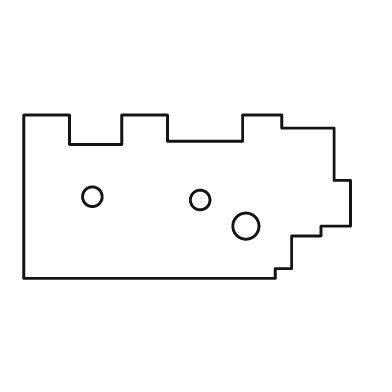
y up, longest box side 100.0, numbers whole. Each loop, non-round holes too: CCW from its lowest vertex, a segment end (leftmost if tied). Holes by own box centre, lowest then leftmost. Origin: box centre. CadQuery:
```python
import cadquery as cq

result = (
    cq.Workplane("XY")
    .moveTo(-50.0, -25.0)
    .lineTo(27.0, -25.0)
    .lineTo(27.0, -22.0)
    .lineTo(32.0, -22.0)
    .lineTo(32.0, -12.0)
    .lineTo(41.0, -12.0)
    .lineTo(41.0, -9.0)
    .lineTo(50.0, -9.0)
    .lineTo(50.0, 5.0)
    .lineTo(45.0, 5.0)
    .lineTo(45.0, 21.0)
    .lineTo(29.0, 21.0)
    .lineTo(29.0, 25.0)
    .lineTo(17.0, 25.0)
    .lineTo(17.0, 17.0)
    .lineTo(-6.0, 17.0)
    .lineTo(-6.0, 25.0)
    .lineTo(-20.0, 25.0)
    .lineTo(-20.0, 16.0)
    .lineTo(-36.0, 16.0)
    .lineTo(-36.0, 25.0)
    .lineTo(-50.0, 25.0)
    .close()
    .moveTo(18.0, -9.0)
    .circle(4.0)
    .moveTo(4.0, -1.0)
    .circle(3.0)
    .moveTo(-29.0, 0.0)
    .circle(3.0)
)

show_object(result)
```